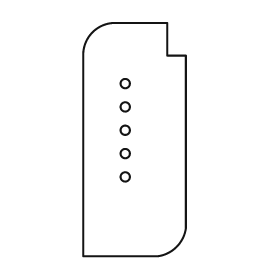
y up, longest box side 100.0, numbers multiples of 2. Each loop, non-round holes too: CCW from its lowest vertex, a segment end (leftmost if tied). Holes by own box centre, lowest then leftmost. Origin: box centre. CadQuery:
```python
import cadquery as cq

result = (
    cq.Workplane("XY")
    .moveTo(-22.0, -50.0)
    .lineTo(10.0, -50.0)
    .threePointArc((18.0, -46.0), (22.0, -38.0))
    .lineTo(22.0, 36.0)
    .lineTo(14.0, 36.0)
    .lineTo(14.0, 50.0)
    .lineTo(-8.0, 50.0)
    .threePointArc((-18.0, 46.0), (-22.0, 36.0))
    .close()
    .moveTo(-4.0, -16.0)
    .circle(2.0)
    .moveTo(-4.0, -6.0)
    .circle(2.0)
    .moveTo(-4.0, 4.0)
    .circle(2.0)
    .moveTo(-4.0, 14.0)
    .circle(2.0)
    .moveTo(-4.0, 24.0)
    .circle(2.0)
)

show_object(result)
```